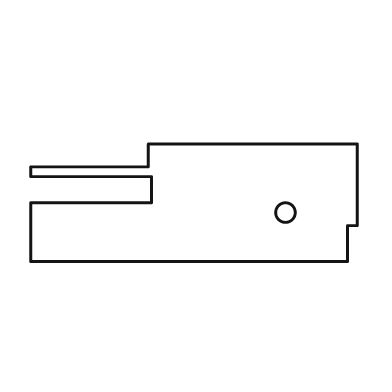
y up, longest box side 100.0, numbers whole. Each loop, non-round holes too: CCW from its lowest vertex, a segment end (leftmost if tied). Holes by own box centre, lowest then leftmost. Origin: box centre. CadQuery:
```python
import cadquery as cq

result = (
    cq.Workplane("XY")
    .moveTo(-50.0, -18.0)
    .lineTo(47.0, -18.0)
    .lineTo(47.0, -7.0)
    .lineTo(50.0, -7.0)
    .lineTo(50.0, 18.0)
    .lineTo(-14.0, 18.0)
    .lineTo(-14.0, 11.0)
    .lineTo(-50.0, 11.0)
    .lineTo(-50.0, 8.0)
    .lineTo(-13.0, 8.0)
    .lineTo(-13.0, 0.0)
    .lineTo(-50.0, 0.0)
    .close()
    .moveTo(28.0, -3.0)
    .circle(3.0)
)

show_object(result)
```